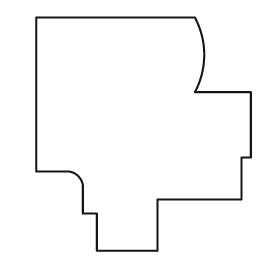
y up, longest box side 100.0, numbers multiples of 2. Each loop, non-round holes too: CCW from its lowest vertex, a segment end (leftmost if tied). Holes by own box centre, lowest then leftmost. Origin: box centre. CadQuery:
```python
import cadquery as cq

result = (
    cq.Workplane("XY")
    .moveTo(-20.0, -50.0)
    .lineTo(6.0, -50.0)
    .lineTo(6.0, -28.0)
    .lineTo(42.0, -28.0)
    .lineTo(42.0, -10.0)
    .lineTo(46.0, -10.0)
    .lineTo(46.0, 18.0)
    .lineTo(22.0, 18.0)
    .threePointArc((26.0, 34.0), (22.0, 50.0))
    .lineTo(-46.0, 50.0)
    .lineTo(-46.0, -16.0)
    .lineTo(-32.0, -16.0)
    .threePointArc((-28.0, -18.0), (-26.0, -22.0))
    .lineTo(-26.0, -34.0)
    .lineTo(-20.0, -34.0)
    .close()
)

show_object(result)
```